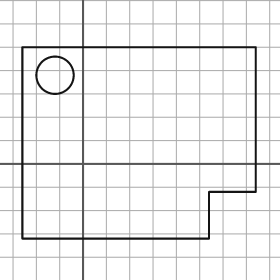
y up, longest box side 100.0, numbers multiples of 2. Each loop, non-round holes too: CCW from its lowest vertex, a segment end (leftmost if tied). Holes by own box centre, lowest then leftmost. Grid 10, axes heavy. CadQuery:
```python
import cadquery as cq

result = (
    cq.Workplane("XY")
    .moveTo(-26.0, -32.0)
    .lineTo(54.0, -32.0)
    .lineTo(54.0, -12.0)
    .lineTo(74.0, -12.0)
    .lineTo(74.0, 50.0)
    .lineTo(-26.0, 50.0)
    .close()
    .moveTo(-12.0, 38.0)
    .circle(8.0)
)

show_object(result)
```